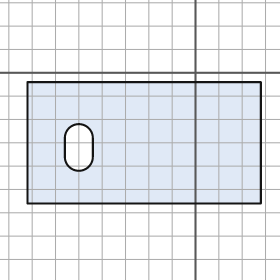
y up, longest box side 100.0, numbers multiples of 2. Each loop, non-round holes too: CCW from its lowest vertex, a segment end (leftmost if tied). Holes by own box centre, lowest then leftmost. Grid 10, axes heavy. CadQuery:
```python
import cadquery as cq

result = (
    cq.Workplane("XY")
    .moveTo(-72.0, -56.0)
    .lineTo(28.0, -56.0)
    .lineTo(28.0, -4.0)
    .lineTo(-72.0, -4.0)
    .close()
    .moveTo(-56.0, -36.0)
    .threePointArc((-50.0, -42.0), (-44.0, -36.0))
    .lineTo(-44.0, -28.0)
    .threePointArc((-50.0, -22.0), (-56.0, -28.0))
    .close()
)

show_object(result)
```